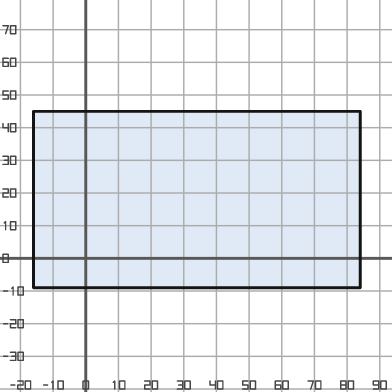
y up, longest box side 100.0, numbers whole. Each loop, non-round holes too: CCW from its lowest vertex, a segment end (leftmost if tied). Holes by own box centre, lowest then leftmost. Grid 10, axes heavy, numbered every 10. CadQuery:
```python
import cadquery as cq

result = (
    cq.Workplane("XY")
    .moveTo(-16.0, -9.0)
    .lineTo(84.0, -9.0)
    .lineTo(84.0, 45.0)
    .lineTo(-16.0, 45.0)
    .close()
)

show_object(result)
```